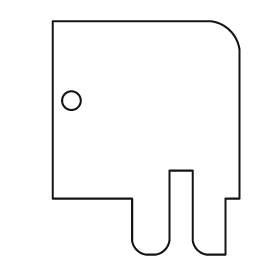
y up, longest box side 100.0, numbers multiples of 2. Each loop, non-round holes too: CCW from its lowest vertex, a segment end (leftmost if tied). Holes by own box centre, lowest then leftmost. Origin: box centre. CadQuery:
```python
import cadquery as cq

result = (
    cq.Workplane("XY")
    .moveTo(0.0, -50.0)
    .lineTo(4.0, -50.0)
    .threePointArc((8.0, -48.0), (10.0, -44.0))
    .lineTo(10.0, -14.0)
    .lineTo(20.0, -14.0)
    .lineTo(20.0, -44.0)
    .threePointArc((22.0, -48.0), (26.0, -50.0))
    .lineTo(34.0, -50.0)
    .lineTo(34.0, -26.0)
    .lineTo(40.0, -26.0)
    .lineTo(40.0, 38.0)
    .threePointArc((36.0, 46.0), (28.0, 50.0))
    .lineTo(-40.0, 50.0)
    .lineTo(-40.0, -26.0)
    .lineTo(-6.0, -26.0)
    .lineTo(-6.0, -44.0)
    .threePointArc((-4.0, -48.0), (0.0, -50.0))
    .close()
    .moveTo(-32.0, 16.0)
    .circle(4.0)
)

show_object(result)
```